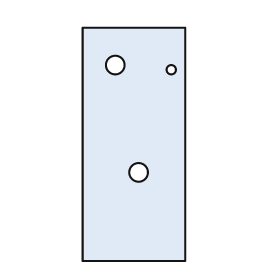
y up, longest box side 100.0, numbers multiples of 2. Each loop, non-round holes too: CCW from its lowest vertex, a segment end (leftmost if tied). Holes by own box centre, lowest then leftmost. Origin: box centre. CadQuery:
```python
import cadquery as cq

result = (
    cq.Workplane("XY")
    .moveTo(-22.0, -50.0)
    .lineTo(22.0, -50.0)
    .lineTo(22.0, 50.0)
    .lineTo(-22.0, 50.0)
    .close()
    .moveTo(2.0, -12.0)
    .circle(4.0)
    .moveTo(16.0, 32.0)
    .circle(2.0)
    .moveTo(-8.0, 34.0)
    .circle(4.0)
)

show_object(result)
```